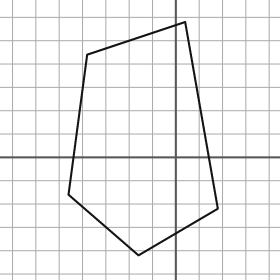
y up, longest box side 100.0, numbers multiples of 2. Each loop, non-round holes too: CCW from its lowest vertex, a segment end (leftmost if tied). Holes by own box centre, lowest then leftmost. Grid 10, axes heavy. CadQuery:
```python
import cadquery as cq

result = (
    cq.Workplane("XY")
    .moveTo(-16.0, -42.0)
    .lineTo(18.0, -22.0)
    .lineTo(4.0, 58.0)
    .lineTo(-38.0, 44.0)
    .lineTo(-46.0, -16.0)
    .close()
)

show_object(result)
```